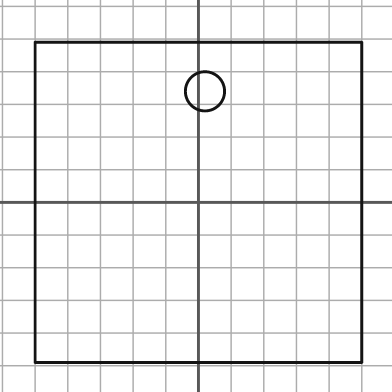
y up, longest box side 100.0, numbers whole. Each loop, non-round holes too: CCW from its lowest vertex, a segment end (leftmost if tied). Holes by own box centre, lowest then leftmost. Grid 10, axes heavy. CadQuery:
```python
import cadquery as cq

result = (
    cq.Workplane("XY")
    .moveTo(-50.0, -49.0)
    .lineTo(50.0, -49.0)
    .lineTo(50.0, 49.0)
    .lineTo(-50.0, 49.0)
    .close()
    .moveTo(2.0, 34.0)
    .circle(6.0)
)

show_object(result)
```